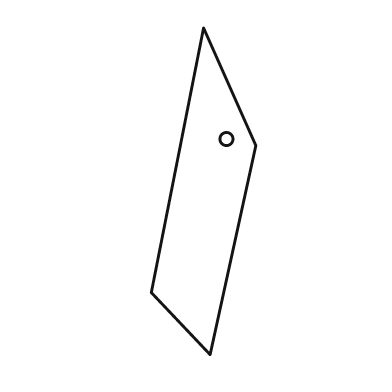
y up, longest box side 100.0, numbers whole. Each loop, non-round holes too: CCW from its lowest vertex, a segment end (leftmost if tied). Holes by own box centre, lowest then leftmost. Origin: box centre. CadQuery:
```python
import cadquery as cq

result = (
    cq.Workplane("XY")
    .moveTo(2.0, -50.0)
    .lineTo(16.0, 14.0)
    .lineTo(0.0, 50.0)
    .lineTo(-16.0, -31.0)
    .close()
    .moveTo(7.0, 16.0)
    .circle(2.0)
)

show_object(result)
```